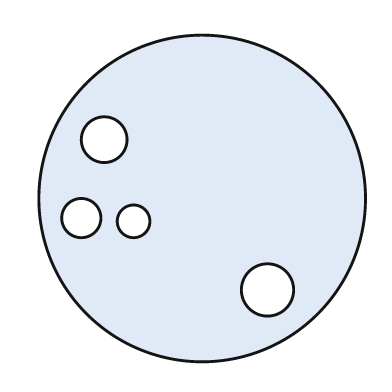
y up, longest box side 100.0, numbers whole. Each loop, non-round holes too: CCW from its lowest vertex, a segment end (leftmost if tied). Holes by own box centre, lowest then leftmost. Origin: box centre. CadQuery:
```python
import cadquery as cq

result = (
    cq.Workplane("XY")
    .moveTo(0.0, 0.0)
    .circle(50.0)
    .moveTo(20.0, -28.0)
    .circle(8.0)
    .moveTo(-21.0, -7.0)
    .circle(5.0)
    .moveTo(-37.0, -6.0)
    .circle(6.0)
    .moveTo(-30.0, 18.0)
    .circle(7.0)
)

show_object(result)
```